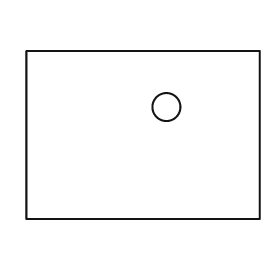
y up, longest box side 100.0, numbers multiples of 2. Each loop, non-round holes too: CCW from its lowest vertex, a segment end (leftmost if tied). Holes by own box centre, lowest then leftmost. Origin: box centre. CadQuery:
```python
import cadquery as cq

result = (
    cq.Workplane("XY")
    .moveTo(-50.0, -36.0)
    .lineTo(50.0, -36.0)
    .lineTo(50.0, 36.0)
    .lineTo(-50.0, 36.0)
    .close()
    .moveTo(10.0, 12.0)
    .circle(6.0)
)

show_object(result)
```